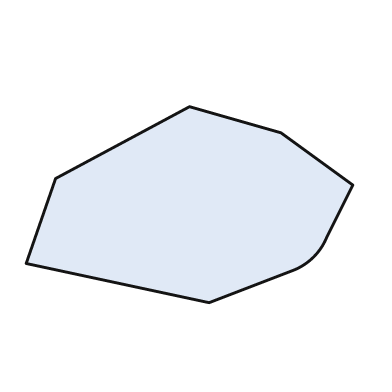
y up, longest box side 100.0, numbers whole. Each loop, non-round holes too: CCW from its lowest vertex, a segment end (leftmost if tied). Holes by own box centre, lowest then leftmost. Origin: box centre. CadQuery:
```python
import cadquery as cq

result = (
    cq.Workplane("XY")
    .moveTo(6.0, -30.0)
    .lineTo(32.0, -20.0)
    .threePointArc((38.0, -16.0), (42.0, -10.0))
    .lineTo(50.0, 6.0)
    .lineTo(28.0, 22.0)
    .lineTo(0.0, 30.0)
    .lineTo(-41.0, 8.0)
    .lineTo(-50.0, -18.0)
    .close()
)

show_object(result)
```